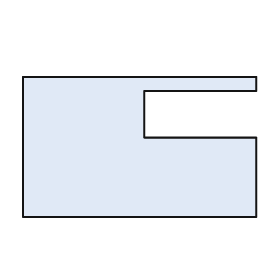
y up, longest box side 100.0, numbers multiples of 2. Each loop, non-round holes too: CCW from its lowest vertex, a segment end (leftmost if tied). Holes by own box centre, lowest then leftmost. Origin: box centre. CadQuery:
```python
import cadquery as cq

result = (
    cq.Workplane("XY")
    .moveTo(-50.0, -30.0)
    .lineTo(50.0, -30.0)
    .lineTo(50.0, 4.0)
    .lineTo(2.0, 4.0)
    .lineTo(2.0, 24.0)
    .lineTo(50.0, 24.0)
    .lineTo(50.0, 30.0)
    .lineTo(-50.0, 30.0)
    .close()
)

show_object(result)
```